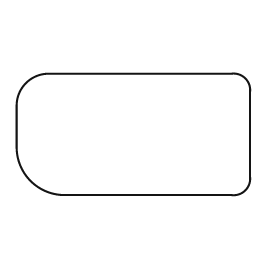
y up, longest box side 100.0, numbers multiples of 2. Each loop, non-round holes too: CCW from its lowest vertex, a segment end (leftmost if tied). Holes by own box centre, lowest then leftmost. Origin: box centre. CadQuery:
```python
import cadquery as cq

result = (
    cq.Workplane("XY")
    .moveTo(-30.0, -26.0)
    .lineTo(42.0, -26.0)
    .threePointArc((48.0, -24.0), (50.0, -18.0))
    .lineTo(50.0, 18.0)
    .threePointArc((48.0, 24.0), (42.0, 26.0))
    .lineTo(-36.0, 26.0)
    .threePointArc((-46.0, 22.0), (-50.0, 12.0))
    .lineTo(-50.0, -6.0)
    .threePointArc((-44.0, -20.0), (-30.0, -26.0))
    .close()
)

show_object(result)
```